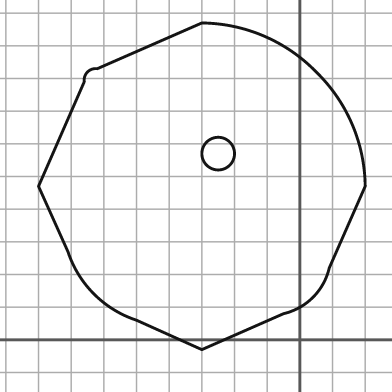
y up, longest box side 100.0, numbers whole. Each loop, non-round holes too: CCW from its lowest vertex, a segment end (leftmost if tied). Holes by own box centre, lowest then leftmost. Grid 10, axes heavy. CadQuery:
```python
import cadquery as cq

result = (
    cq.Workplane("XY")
    .moveTo(-30.0, -3.0)
    .lineTo(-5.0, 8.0)
    .threePointArc((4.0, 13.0), (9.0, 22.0))
    .lineTo(20.0, 47.0)
    .threePointArc((16.0, 66.0), (5.0, 82.0))
    .threePointArc((-11.0, 93.0), (-30.0, 97.0))
    .lineTo(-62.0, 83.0)
    .threePointArc((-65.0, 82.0), (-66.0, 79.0))
    .lineTo(-80.0, 47.0)
    .lineTo(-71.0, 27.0)
    .threePointArc((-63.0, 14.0), (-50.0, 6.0))
    .close()
    .moveTo(-25.0, 57.0)
    .circle(5.0)
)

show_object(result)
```